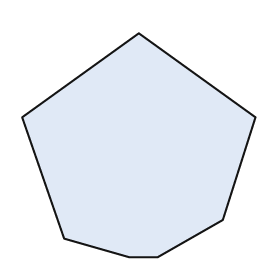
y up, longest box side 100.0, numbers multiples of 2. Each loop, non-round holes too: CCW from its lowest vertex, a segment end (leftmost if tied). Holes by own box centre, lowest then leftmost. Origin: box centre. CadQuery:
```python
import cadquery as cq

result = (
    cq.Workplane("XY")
    .moveTo(-4.0, -48.0)
    .lineTo(8.0, -48.0)
    .lineTo(36.0, -32.0)
    .lineTo(50.0, 12.0)
    .lineTo(0.0, 48.0)
    .lineTo(-50.0, 12.0)
    .lineTo(-32.0, -40.0)
    .close()
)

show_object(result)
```